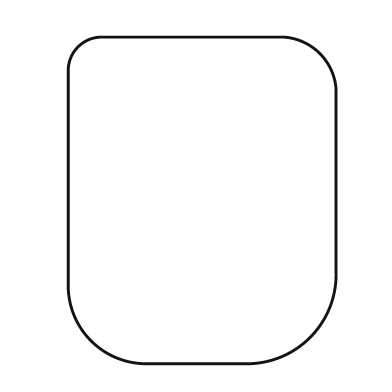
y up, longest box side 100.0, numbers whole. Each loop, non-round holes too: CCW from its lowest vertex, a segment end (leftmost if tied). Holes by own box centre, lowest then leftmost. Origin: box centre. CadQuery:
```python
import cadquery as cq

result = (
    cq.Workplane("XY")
    .moveTo(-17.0, -50.0)
    .lineTo(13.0, -50.0)
    .threePointArc((33.0, -42.0), (41.0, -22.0))
    .lineTo(41.0, 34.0)
    .threePointArc((36.0, 45.0), (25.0, 50.0))
    .lineTo(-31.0, 50.0)
    .threePointArc((-38.0, 47.0), (-41.0, 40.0))
    .lineTo(-41.0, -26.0)
    .threePointArc((-34.0, -43.0), (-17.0, -50.0))
    .close()
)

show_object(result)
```